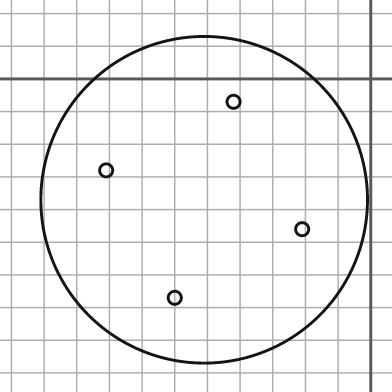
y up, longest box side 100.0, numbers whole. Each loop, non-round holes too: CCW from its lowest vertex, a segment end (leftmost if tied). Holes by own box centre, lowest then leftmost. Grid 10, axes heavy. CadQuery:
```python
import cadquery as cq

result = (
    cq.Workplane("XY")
    .moveTo(-51.0, -37.0)
    .circle(50.0)
    .moveTo(-60.0, -67.0)
    .circle(2.0)
    .moveTo(-21.0, -46.0)
    .circle(2.0)
    .moveTo(-81.0, -28.0)
    .circle(2.0)
    .moveTo(-42.0, -7.0)
    .circle(2.0)
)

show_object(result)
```